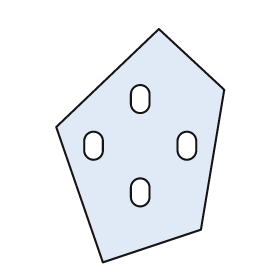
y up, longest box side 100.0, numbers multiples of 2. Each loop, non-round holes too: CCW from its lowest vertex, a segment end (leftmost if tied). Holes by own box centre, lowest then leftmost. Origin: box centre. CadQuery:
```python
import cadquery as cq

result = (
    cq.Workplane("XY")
    .moveTo(-16.0, -50.0)
    .lineTo(26.0, -36.0)
    .lineTo(36.0, 24.0)
    .lineTo(8.0, 50.0)
    .lineTo(-36.0, 8.0)
    .close()
    .moveTo(-4.0, -22.0)
    .threePointArc((0.0, -26.0), (4.0, -22.0))
    .lineTo(4.0, -18.0)
    .threePointArc((0.0, -14.0), (-4.0, -18.0))
    .close()
    .moveTo(-24.0, -2.0)
    .threePointArc((-20.0, -6.0), (-16.0, -2.0))
    .lineTo(-16.0, 2.0)
    .threePointArc((-20.0, 6.0), (-24.0, 2.0))
    .close()
    .moveTo(16.0, -2.0)
    .threePointArc((20.0, -6.0), (24.0, -2.0))
    .lineTo(24.0, 2.0)
    .threePointArc((20.0, 6.0), (16.0, 2.0))
    .close()
    .moveTo(-4.0, 18.0)
    .threePointArc((0.0, 14.0), (4.0, 18.0))
    .lineTo(4.0, 22.0)
    .threePointArc((0.0, 26.0), (-4.0, 22.0))
    .close()
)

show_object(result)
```